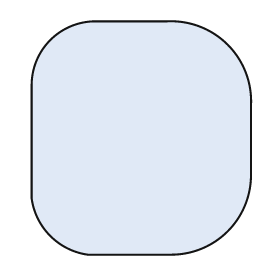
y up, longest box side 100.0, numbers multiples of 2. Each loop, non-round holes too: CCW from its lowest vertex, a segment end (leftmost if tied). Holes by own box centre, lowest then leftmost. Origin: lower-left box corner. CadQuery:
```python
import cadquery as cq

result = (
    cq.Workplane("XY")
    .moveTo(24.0, 0.0)
    .lineTo(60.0, 0.0)
    .threePointArc((84.0, 10.0), (94.0, 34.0))
    .lineTo(94.0, 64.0)
    .threePointArc((84.0, 90.0), (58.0, 100.0))
    .lineTo(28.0, 100.0)
    .threePointArc((8.0, 92.0), (0.0, 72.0))
    .lineTo(0.0, 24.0)
    .threePointArc((8.0, 8.0), (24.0, 0.0))
    .close()
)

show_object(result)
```